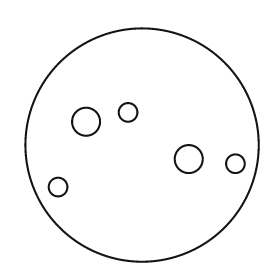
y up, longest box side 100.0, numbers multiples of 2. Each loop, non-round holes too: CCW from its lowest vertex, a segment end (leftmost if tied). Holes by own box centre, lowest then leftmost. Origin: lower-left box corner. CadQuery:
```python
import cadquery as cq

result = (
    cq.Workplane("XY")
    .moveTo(50.0, 50.0)
    .circle(50.0)
    .moveTo(14.0, 32.0)
    .circle(4.0)
    .moveTo(90.0, 42.0)
    .circle(4.0)
    .moveTo(70.0, 44.0)
    .circle(6.0)
    .moveTo(26.0, 60.0)
    .circle(6.0)
    .moveTo(44.0, 64.0)
    .circle(4.0)
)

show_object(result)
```